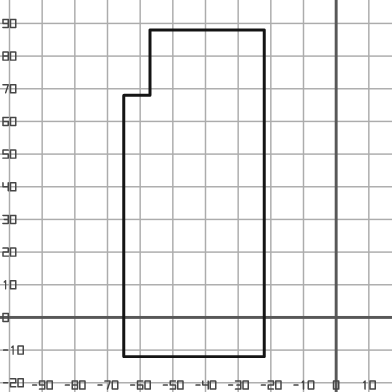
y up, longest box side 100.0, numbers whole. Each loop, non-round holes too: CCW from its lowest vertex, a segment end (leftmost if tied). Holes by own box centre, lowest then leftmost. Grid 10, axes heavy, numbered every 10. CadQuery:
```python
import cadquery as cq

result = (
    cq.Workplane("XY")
    .moveTo(-65.0, -12.0)
    .lineTo(-22.0, -12.0)
    .lineTo(-22.0, 88.0)
    .lineTo(-57.0, 88.0)
    .lineTo(-57.0, 68.0)
    .lineTo(-65.0, 68.0)
    .close()
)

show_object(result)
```